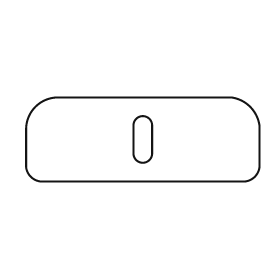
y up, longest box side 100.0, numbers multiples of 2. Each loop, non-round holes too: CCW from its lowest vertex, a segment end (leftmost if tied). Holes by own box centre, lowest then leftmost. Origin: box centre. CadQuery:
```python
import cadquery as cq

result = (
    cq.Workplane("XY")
    .moveTo(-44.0, -18.0)
    .lineTo(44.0, -18.0)
    .threePointArc((48.0, -16.0), (50.0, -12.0))
    .lineTo(50.0, 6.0)
    .threePointArc((46.0, 14.0), (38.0, 18.0))
    .lineTo(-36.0, 18.0)
    .threePointArc((-46.0, 14.0), (-50.0, 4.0))
    .lineTo(-50.0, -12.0)
    .threePointArc((-48.0, -16.0), (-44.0, -18.0))
    .close()
    .moveTo(-4.0, -6.0)
    .threePointArc((0.0, -10.0), (4.0, -6.0))
    .lineTo(4.0, 6.0)
    .threePointArc((0.0, 10.0), (-4.0, 6.0))
    .close()
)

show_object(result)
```